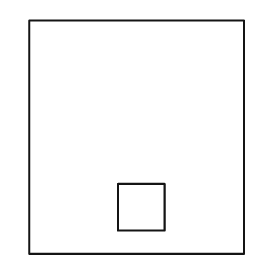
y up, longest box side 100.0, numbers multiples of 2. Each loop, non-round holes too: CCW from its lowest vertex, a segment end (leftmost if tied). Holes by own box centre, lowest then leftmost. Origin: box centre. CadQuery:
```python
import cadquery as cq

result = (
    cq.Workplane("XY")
    .moveTo(-46.0, -50.0)
    .lineTo(46.0, -50.0)
    .lineTo(46.0, 50.0)
    .lineTo(-46.0, 50.0)
    .close()
    .moveTo(-8.0, -40.0)
    .lineTo(12.0, -40.0)
    .lineTo(12.0, -20.0)
    .lineTo(-8.0, -20.0)
    .close()
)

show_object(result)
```